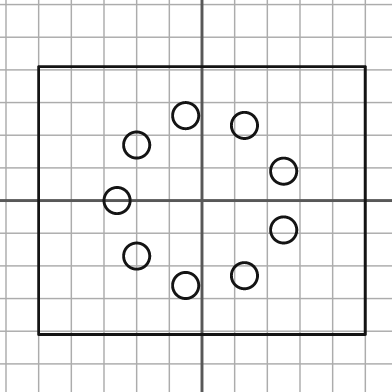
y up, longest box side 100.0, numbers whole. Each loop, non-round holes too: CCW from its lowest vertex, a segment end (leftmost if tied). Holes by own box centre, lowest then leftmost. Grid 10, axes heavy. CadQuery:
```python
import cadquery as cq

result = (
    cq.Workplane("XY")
    .moveTo(-50.0, -41.0)
    .lineTo(50.0, -41.0)
    .lineTo(50.0, 41.0)
    .lineTo(-50.0, 41.0)
    .close()
    .moveTo(-5.0, -26.0)
    .circle(4.0)
    .moveTo(13.0, -23.0)
    .circle(4.0)
    .moveTo(-20.0, -17.0)
    .circle(4.0)
    .moveTo(25.0, -9.0)
    .circle(4.0)
    .moveTo(-26.0, 0.0)
    .circle(4.0)
    .moveTo(25.0, 9.0)
    .circle(4.0)
    .moveTo(-20.0, 17.0)
    .circle(4.0)
    .moveTo(13.0, 23.0)
    .circle(4.0)
    .moveTo(-5.0, 26.0)
    .circle(4.0)
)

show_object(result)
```